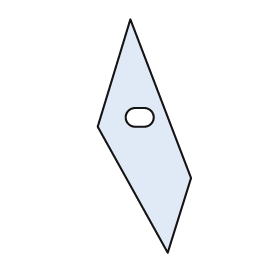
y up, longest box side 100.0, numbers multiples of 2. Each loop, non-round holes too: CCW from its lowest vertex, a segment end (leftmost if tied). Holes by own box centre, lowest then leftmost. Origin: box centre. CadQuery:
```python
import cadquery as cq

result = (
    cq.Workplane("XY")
    .moveTo(10.0, -50.0)
    .lineTo(20.0, -18.0)
    .lineTo(-6.0, 50.0)
    .lineTo(-20.0, 4.0)
    .close()
    .moveTo(-4.0, 4.0)
    .lineTo(0.0, 4.0)
    .threePointArc((4.0, 8.0), (0.0, 12.0))
    .lineTo(-4.0, 12.0)
    .threePointArc((-8.0, 8.0), (-4.0, 4.0))
    .close()
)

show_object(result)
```